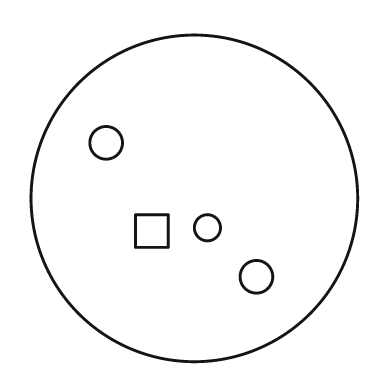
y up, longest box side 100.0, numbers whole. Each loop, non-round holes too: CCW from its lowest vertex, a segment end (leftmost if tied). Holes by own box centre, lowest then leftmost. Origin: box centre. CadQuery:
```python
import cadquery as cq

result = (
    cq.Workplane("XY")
    .moveTo(0.0, 0.0)
    .circle(50.0)
    .moveTo(19.0, -24.0)
    .circle(5.0)
    .moveTo(-18.0, -15.0)
    .lineTo(-8.0, -15.0)
    .lineTo(-8.0, -5.0)
    .lineTo(-18.0, -5.0)
    .close()
    .moveTo(4.0, -9.0)
    .circle(4.0)
    .moveTo(-27.0, 17.0)
    .circle(5.0)
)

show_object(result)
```